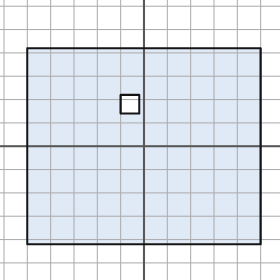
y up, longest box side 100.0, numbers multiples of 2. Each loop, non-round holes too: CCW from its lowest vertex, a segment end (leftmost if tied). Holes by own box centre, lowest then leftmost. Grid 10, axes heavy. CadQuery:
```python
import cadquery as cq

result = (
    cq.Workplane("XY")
    .moveTo(-50.0, -42.0)
    .lineTo(50.0, -42.0)
    .lineTo(50.0, 42.0)
    .lineTo(-50.0, 42.0)
    .close()
    .moveTo(-10.0, 14.0)
    .lineTo(-2.0, 14.0)
    .lineTo(-2.0, 22.0)
    .lineTo(-10.0, 22.0)
    .close()
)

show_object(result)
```